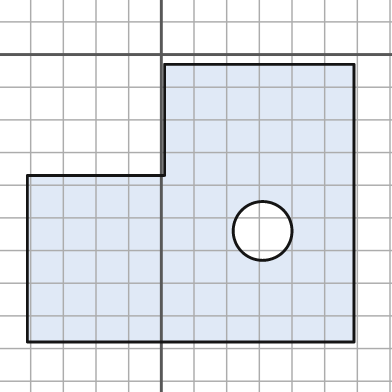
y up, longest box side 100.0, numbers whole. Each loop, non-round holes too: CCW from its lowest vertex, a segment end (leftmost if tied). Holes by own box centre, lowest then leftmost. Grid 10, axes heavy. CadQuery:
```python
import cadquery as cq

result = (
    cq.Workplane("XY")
    .moveTo(-41.0, -88.0)
    .lineTo(59.0, -88.0)
    .lineTo(59.0, -3.0)
    .lineTo(1.0, -3.0)
    .lineTo(1.0, -37.0)
    .lineTo(-41.0, -37.0)
    .close()
    .moveTo(31.0, -54.0)
    .circle(9.0)
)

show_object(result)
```